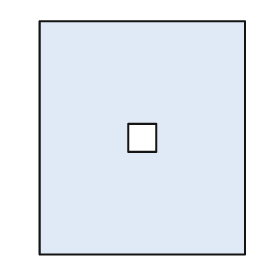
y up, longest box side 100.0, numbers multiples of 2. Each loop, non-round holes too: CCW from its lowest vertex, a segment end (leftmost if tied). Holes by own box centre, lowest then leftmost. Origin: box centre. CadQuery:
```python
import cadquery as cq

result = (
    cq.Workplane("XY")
    .moveTo(-44.0, -50.0)
    .lineTo(44.0, -50.0)
    .lineTo(44.0, 50.0)
    .lineTo(-44.0, 50.0)
    .close()
    .moveTo(-6.0, -6.0)
    .lineTo(6.0, -6.0)
    .lineTo(6.0, 6.0)
    .lineTo(-6.0, 6.0)
    .close()
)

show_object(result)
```